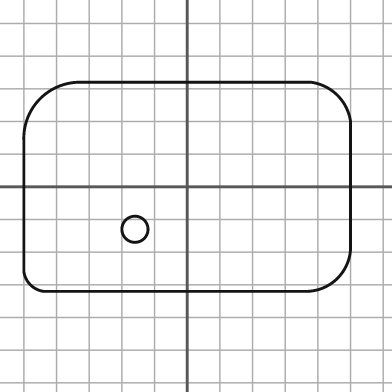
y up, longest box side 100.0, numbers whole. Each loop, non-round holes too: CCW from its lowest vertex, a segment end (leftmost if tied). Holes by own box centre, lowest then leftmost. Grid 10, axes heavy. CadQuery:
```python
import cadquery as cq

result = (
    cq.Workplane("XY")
    .moveTo(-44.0, -32.0)
    .lineTo(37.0, -32.0)
    .threePointArc((46.0, -28.0), (50.0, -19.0))
    .lineTo(50.0, 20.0)
    .threePointArc((46.0, 28.0), (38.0, 32.0))
    .lineTo(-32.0, 32.0)
    .threePointArc((-45.0, 27.0), (-50.0, 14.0))
    .lineTo(-50.0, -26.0)
    .threePointArc((-48.0, -30.0), (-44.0, -32.0))
    .close()
    .moveTo(-16.0, -13.0)
    .circle(4.0)
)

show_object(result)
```